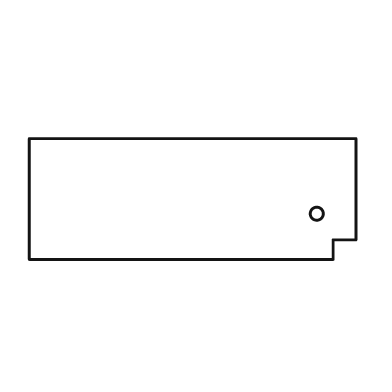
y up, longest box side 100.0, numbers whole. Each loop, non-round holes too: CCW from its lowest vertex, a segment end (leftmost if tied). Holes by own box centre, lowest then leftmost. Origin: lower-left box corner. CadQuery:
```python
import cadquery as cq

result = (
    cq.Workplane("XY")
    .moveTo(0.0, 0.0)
    .lineTo(93.0, 0.0)
    .lineTo(93.0, 6.0)
    .lineTo(100.0, 6.0)
    .lineTo(100.0, 37.0)
    .lineTo(0.0, 37.0)
    .close()
    .moveTo(88.0, 14.0)
    .circle(2.0)
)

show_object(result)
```